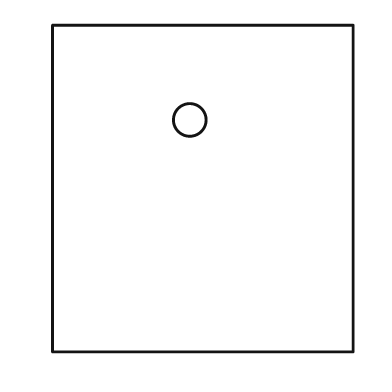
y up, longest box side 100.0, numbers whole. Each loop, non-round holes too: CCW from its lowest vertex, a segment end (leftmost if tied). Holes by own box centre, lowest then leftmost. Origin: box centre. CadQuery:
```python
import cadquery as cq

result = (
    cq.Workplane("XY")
    .moveTo(-46.0, -50.0)
    .lineTo(46.0, -50.0)
    .lineTo(46.0, 50.0)
    .lineTo(-46.0, 50.0)
    .close()
    .moveTo(-4.0, 21.0)
    .circle(5.0)
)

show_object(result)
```